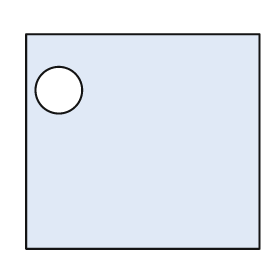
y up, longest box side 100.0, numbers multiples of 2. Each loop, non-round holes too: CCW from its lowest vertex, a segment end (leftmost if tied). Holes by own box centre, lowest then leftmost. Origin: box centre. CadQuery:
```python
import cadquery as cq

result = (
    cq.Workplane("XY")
    .moveTo(-50.0, -46.0)
    .lineTo(50.0, -46.0)
    .lineTo(50.0, 46.0)
    .lineTo(-50.0, 46.0)
    .close()
    .moveTo(-36.0, 22.0)
    .circle(10.0)
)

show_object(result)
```